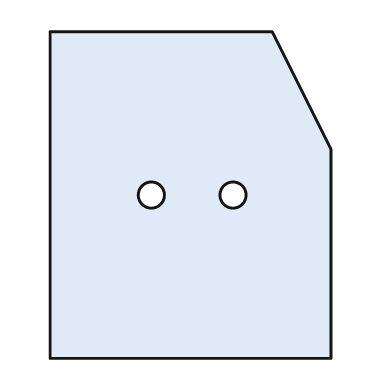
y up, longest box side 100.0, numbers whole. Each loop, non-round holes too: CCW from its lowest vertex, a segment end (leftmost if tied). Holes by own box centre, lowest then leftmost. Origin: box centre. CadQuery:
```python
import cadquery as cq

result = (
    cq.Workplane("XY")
    .moveTo(-43.0, -50.0)
    .lineTo(43.0, -50.0)
    .lineTo(43.0, 14.0)
    .lineTo(25.0, 50.0)
    .lineTo(-43.0, 50.0)
    .close()
    .moveTo(-12.0, 0.0)
    .circle(4.0)
    .moveTo(13.0, 0.0)
    .circle(4.0)
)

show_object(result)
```